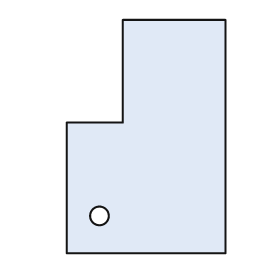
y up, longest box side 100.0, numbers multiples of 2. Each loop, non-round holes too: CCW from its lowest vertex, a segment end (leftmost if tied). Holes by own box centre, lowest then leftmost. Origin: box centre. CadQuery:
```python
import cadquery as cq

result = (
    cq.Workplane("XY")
    .moveTo(-34.0, -50.0)
    .lineTo(34.0, -50.0)
    .lineTo(34.0, 50.0)
    .lineTo(-10.0, 50.0)
    .lineTo(-10.0, 6.0)
    .lineTo(-34.0, 6.0)
    .close()
    .moveTo(-20.0, -34.0)
    .circle(4.0)
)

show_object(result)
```